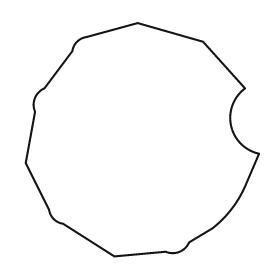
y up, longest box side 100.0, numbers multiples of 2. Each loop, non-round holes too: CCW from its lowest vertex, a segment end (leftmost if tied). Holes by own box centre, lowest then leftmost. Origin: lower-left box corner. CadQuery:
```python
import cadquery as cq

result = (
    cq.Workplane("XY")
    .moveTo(38.0, 0.0)
    .lineTo(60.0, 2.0)
    .threePointArc((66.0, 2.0), (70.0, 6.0))
    .lineTo(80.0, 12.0)
    .threePointArc((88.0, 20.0), (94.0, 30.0))
    .lineTo(100.0, 44.0)
    .threePointArc((88.0, 56.0), (94.0, 72.0))
    .lineTo(76.0, 92.0)
    .lineTo(48.0, 100.0)
    .lineTo(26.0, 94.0)
    .threePointArc((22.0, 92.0), (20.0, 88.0))
    .lineTo(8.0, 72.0)
    .threePointArc((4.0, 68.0), (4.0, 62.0))
    .lineTo(0.0, 40.0)
    .lineTo(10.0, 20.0)
    .threePointArc((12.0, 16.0), (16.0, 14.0))
    .close()
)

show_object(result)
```